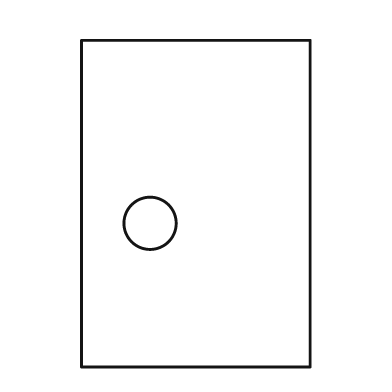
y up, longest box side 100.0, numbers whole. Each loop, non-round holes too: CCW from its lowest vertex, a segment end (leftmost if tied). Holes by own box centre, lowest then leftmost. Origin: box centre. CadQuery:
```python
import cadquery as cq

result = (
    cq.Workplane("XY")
    .moveTo(-35.0, -50.0)
    .lineTo(35.0, -50.0)
    .lineTo(35.0, 50.0)
    .lineTo(-35.0, 50.0)
    .close()
    .moveTo(-14.0, -6.0)
    .circle(8.0)
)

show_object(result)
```